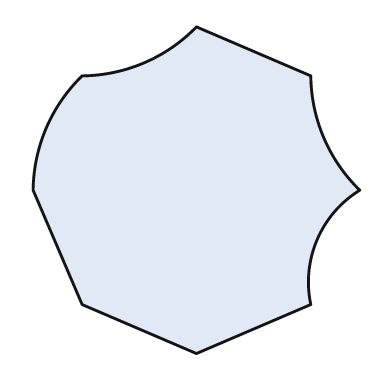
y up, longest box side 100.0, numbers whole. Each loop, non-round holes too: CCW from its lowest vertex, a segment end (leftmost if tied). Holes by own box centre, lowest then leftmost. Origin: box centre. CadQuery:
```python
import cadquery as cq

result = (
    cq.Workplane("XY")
    .moveTo(0.0, -50.0)
    .lineTo(35.0, -35.0)
    .threePointArc((37.0, -15.0), (50.0, 0.0))
    .threePointArc((39.0, 16.0), (35.0, 35.0))
    .lineTo(0.0, 50.0)
    .threePointArc((-16.0, 39.0), (-35.0, 35.0))
    .threePointArc((-46.0, 19.0), (-50.0, 0.0))
    .lineTo(-35.0, -35.0)
    .close()
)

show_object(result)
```